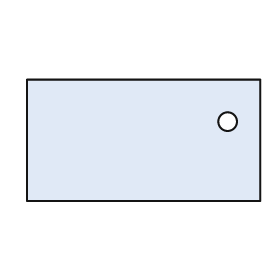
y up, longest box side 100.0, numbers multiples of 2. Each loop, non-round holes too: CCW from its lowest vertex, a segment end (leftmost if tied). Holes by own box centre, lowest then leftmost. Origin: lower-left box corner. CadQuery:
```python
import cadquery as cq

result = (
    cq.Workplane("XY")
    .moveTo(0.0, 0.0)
    .lineTo(100.0, 0.0)
    .lineTo(100.0, 52.0)
    .lineTo(0.0, 52.0)
    .close()
    .moveTo(86.0, 34.0)
    .circle(4.0)
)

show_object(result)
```